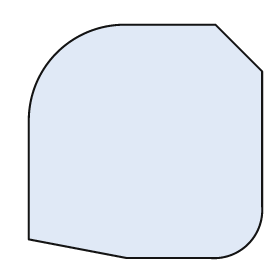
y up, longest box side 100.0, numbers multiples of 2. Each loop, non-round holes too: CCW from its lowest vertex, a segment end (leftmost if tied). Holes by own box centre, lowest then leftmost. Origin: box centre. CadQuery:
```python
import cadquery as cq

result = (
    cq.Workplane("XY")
    .moveTo(-8.0, -50.0)
    .lineTo(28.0, -50.0)
    .threePointArc((44.0, -44.0), (50.0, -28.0))
    .lineTo(50.0, 30.0)
    .lineTo(30.0, 50.0)
    .lineTo(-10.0, 50.0)
    .threePointArc((-38.0, 38.0), (-50.0, 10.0))
    .lineTo(-50.0, -42.0)
    .close()
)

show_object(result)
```